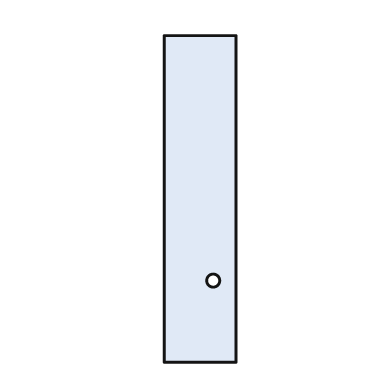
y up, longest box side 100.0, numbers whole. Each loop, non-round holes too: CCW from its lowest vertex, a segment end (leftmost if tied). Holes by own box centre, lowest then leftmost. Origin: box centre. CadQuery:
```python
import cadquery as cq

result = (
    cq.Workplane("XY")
    .moveTo(-11.0, -50.0)
    .lineTo(11.0, -50.0)
    .lineTo(11.0, 50.0)
    .lineTo(-11.0, 50.0)
    .close()
    .moveTo(4.0, -25.0)
    .circle(2.0)
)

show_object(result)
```